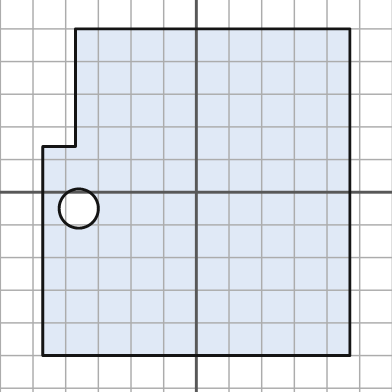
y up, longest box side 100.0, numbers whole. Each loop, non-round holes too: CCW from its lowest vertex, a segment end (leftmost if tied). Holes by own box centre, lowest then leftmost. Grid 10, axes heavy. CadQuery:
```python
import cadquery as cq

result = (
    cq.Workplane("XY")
    .moveTo(-47.0, -50.0)
    .lineTo(47.0, -50.0)
    .lineTo(47.0, 50.0)
    .lineTo(-37.0, 50.0)
    .lineTo(-37.0, 14.0)
    .lineTo(-47.0, 14.0)
    .close()
    .moveTo(-36.0, -5.0)
    .circle(6.0)
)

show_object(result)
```